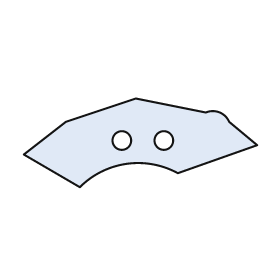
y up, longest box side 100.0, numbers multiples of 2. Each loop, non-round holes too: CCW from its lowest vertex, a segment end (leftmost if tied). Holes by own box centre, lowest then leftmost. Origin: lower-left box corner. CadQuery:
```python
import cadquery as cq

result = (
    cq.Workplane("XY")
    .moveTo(24.0, 0.0)
    .threePointArc((44.0, 10.0), (66.0, 6.0))
    .lineTo(100.0, 18.0)
    .lineTo(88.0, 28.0)
    .threePointArc((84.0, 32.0), (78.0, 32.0))
    .lineTo(48.0, 38.0)
    .lineTo(18.0, 28.0)
    .lineTo(0.0, 14.0)
    .close()
    .moveTo(42.0, 20.0)
    .circle(4.0)
    .moveTo(60.0, 20.0)
    .circle(4.0)
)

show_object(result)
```